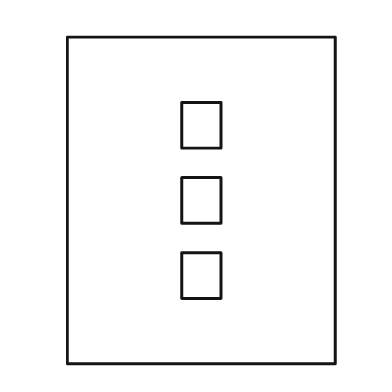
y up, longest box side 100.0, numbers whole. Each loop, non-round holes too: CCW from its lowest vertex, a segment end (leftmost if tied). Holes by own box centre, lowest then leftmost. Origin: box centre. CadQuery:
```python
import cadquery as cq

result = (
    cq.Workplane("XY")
    .moveTo(-41.0, -50.0)
    .lineTo(41.0, -50.0)
    .lineTo(41.0, 50.0)
    .lineTo(-41.0, 50.0)
    .close()
    .moveTo(-6.0, -30.0)
    .lineTo(6.0, -30.0)
    .lineTo(6.0, -16.0)
    .lineTo(-6.0, -16.0)
    .close()
    .moveTo(-6.0, -7.0)
    .lineTo(6.0, -7.0)
    .lineTo(6.0, 7.0)
    .lineTo(-6.0, 7.0)
    .close()
    .moveTo(-6.0, 16.0)
    .lineTo(6.0, 16.0)
    .lineTo(6.0, 30.0)
    .lineTo(-6.0, 30.0)
    .close()
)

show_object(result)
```